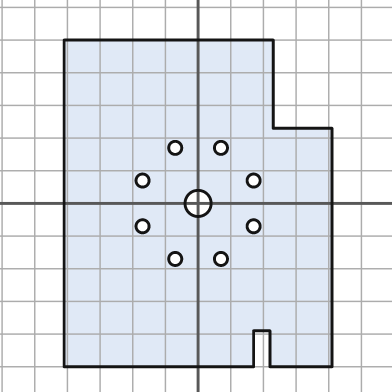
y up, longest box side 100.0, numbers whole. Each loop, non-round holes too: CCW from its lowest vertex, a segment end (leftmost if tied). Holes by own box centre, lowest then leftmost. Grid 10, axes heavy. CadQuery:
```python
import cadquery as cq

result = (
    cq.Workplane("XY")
    .moveTo(-41.0, -50.0)
    .lineTo(17.0, -50.0)
    .lineTo(17.0, -39.0)
    .lineTo(22.0, -39.0)
    .lineTo(22.0, -50.0)
    .lineTo(41.0, -50.0)
    .lineTo(41.0, 23.0)
    .lineTo(23.0, 23.0)
    .lineTo(23.0, 50.0)
    .lineTo(-41.0, 50.0)
    .close()
    .moveTo(-7.0, -17.0)
    .circle(2.0)
    .moveTo(7.0, -17.0)
    .circle(2.0)
    .moveTo(-17.0, -7.0)
    .circle(2.0)
    .moveTo(17.0, -7.0)
    .circle(2.0)
    .moveTo(0.0, 0.0)
    .circle(4.0)
    .moveTo(-17.0, 7.0)
    .circle(2.0)
    .moveTo(17.0, 7.0)
    .circle(2.0)
    .moveTo(-7.0, 17.0)
    .circle(2.0)
    .moveTo(7.0, 17.0)
    .circle(2.0)
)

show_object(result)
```